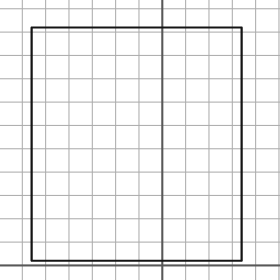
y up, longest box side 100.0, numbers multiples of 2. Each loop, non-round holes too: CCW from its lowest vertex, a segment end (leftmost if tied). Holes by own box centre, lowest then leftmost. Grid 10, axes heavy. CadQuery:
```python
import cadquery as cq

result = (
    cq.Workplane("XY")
    .moveTo(-56.0, 2.0)
    .lineTo(34.0, 2.0)
    .lineTo(34.0, 102.0)
    .lineTo(-56.0, 102.0)
    .close()
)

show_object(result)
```